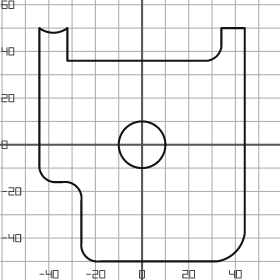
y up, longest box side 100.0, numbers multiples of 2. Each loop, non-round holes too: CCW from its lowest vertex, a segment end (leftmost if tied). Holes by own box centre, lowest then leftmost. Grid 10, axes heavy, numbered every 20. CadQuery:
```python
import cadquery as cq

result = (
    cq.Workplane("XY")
    .moveTo(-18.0, -50.0)
    .lineTo(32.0, -50.0)
    .threePointArc((40.0, -46.0), (44.0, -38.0))
    .lineTo(44.0, 50.0)
    .lineTo(34.0, 50.0)
    .lineTo(34.0, 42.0)
    .threePointArc((32.0, 38.0), (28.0, 36.0))
    .lineTo(-32.0, 36.0)
    .lineTo(-32.0, 50.0)
    .threePointArc((-38.0, 48.0), (-44.0, 50.0))
    .lineTo(-44.0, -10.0)
    .threePointArc((-42.0, -14.0), (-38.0, -16.0))
    .lineTo(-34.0, -16.0)
    .threePointArc((-28.0, -18.0), (-26.0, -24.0))
    .lineTo(-26.0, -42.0)
    .threePointArc((-24.0, -48.0), (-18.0, -50.0))
    .close()
    .moveTo(0.0, 0.0)
    .circle(10.0)
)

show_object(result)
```